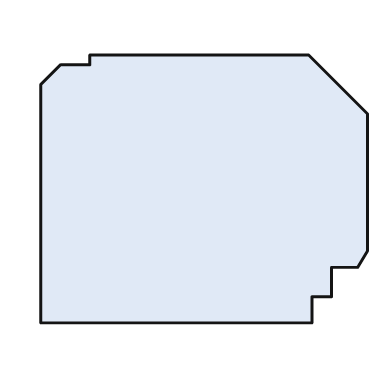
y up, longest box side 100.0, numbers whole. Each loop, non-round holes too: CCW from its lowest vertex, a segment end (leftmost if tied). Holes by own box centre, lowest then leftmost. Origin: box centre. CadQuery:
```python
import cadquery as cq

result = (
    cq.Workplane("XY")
    .moveTo(-50.0, -41.0)
    .lineTo(33.0, -41.0)
    .lineTo(33.0, -33.0)
    .lineTo(39.0, -33.0)
    .lineTo(39.0, -24.0)
    .lineTo(47.0, -24.0)
    .lineTo(50.0, -19.0)
    .lineTo(50.0, 23.0)
    .lineTo(32.0, 41.0)
    .lineTo(-35.0, 41.0)
    .lineTo(-35.0, 38.0)
    .lineTo(-44.0, 38.0)
    .lineTo(-50.0, 32.0)
    .close()
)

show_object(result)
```